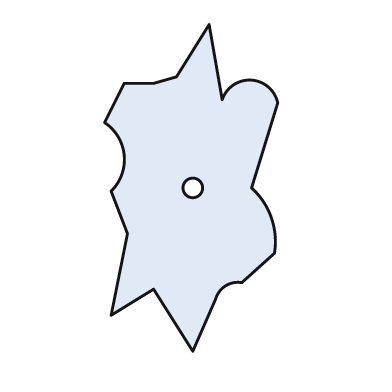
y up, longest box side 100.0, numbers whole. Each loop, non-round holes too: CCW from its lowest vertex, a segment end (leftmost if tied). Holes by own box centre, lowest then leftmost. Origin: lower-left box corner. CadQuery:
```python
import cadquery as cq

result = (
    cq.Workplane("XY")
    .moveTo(27.0, 0.0)
    .lineTo(34.0, 16.0)
    .threePointArc((37.0, 20.0), (42.0, 21.0))
    .lineTo(52.0, 30.0)
    .threePointArc((51.0, 41.0), (45.0, 50.0))
    .lineTo(53.0, 76.0)
    .threePointArc((45.0, 83.0), (36.0, 77.0))
    .lineTo(32.0, 100.0)
    .lineTo(22.0, 84.0)
    .lineTo(15.0, 82.0)
    .lineTo(6.0, 82.0)
    .lineTo(0.0, 70.0)
    .threePointArc((6.0, 60.0), (2.0, 49.0))
    .lineTo(7.0, 36.0)
    .lineTo(2.0, 11.0)
    .lineTo(15.0, 19.0)
    .close()
    .moveTo(27.0, 50.0)
    .circle(3.0)
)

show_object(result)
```